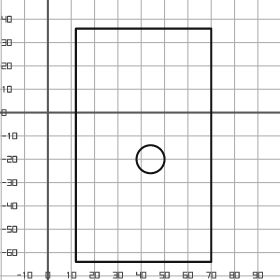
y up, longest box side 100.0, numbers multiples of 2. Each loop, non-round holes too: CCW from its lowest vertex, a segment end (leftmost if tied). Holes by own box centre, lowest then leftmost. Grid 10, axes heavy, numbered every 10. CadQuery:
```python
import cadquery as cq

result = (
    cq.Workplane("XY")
    .moveTo(12.0, -64.0)
    .lineTo(70.0, -64.0)
    .lineTo(70.0, 36.0)
    .lineTo(12.0, 36.0)
    .close()
    .moveTo(44.0, -20.0)
    .circle(6.0)
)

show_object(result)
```